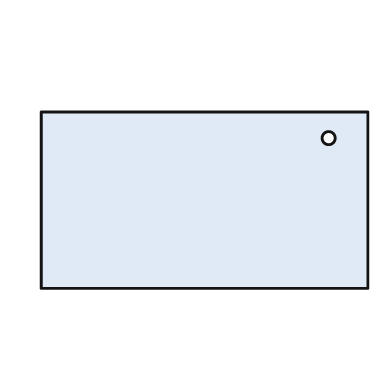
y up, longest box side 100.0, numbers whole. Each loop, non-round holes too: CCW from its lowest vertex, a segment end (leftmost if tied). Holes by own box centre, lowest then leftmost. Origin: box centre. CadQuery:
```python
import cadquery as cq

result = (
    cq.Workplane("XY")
    .moveTo(-50.0, -27.0)
    .lineTo(50.0, -27.0)
    .lineTo(50.0, 27.0)
    .lineTo(-50.0, 27.0)
    .close()
    .moveTo(38.0, 19.0)
    .circle(2.0)
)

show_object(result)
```